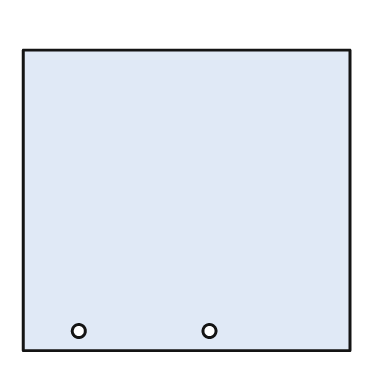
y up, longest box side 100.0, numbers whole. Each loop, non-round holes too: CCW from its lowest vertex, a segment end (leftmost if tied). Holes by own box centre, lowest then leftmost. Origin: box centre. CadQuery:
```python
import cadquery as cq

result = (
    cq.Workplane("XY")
    .moveTo(-50.0, -46.0)
    .lineTo(50.0, -46.0)
    .lineTo(50.0, 46.0)
    .lineTo(-50.0, 46.0)
    .close()
    .moveTo(-33.0, -40.0)
    .circle(2.0)
    .moveTo(7.0, -40.0)
    .circle(2.0)
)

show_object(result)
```